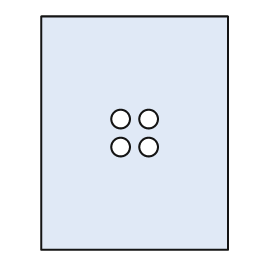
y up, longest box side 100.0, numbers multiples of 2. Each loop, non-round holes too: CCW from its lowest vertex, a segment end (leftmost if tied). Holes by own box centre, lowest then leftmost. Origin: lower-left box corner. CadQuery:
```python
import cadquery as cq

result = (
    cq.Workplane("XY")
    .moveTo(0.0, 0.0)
    .lineTo(80.0, 0.0)
    .lineTo(80.0, 100.0)
    .lineTo(0.0, 100.0)
    .close()
    .moveTo(34.0, 44.0)
    .circle(4.0)
    .moveTo(46.0, 44.0)
    .circle(4.0)
    .moveTo(34.0, 56.0)
    .circle(4.0)
    .moveTo(46.0, 56.0)
    .circle(4.0)
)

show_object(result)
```